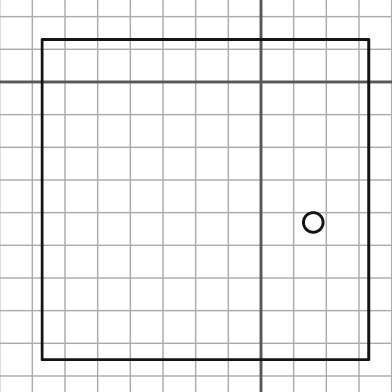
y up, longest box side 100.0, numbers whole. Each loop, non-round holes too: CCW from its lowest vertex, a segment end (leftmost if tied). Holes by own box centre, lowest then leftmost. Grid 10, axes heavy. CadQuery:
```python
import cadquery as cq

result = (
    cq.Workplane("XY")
    .moveTo(-67.0, -85.0)
    .lineTo(33.0, -85.0)
    .lineTo(33.0, 13.0)
    .lineTo(-67.0, 13.0)
    .close()
    .moveTo(16.0, -43.0)
    .circle(3.0)
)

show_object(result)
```